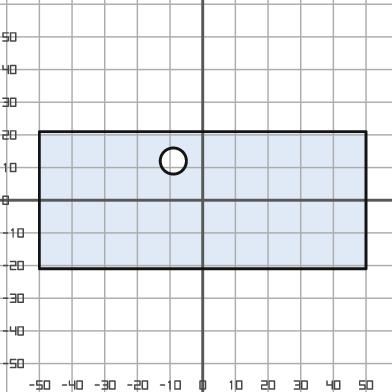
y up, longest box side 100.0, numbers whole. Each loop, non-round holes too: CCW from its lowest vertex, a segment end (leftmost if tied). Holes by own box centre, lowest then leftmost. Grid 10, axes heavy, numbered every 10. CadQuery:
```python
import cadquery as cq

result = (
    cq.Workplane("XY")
    .moveTo(-50.0, -21.0)
    .lineTo(50.0, -21.0)
    .lineTo(50.0, 21.0)
    .lineTo(-50.0, 21.0)
    .close()
    .moveTo(-9.0, 12.0)
    .circle(4.0)
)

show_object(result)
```